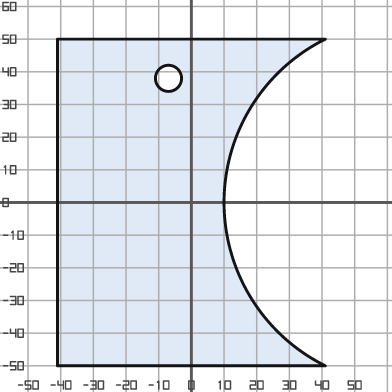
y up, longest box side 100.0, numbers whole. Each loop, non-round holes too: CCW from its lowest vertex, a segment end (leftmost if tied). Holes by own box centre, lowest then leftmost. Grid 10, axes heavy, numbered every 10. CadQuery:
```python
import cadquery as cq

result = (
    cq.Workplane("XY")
    .moveTo(-41.0, -50.0)
    .lineTo(41.0, -50.0)
    .threePointArc((10.0, 0.0), (41.0, 50.0))
    .lineTo(-41.0, 50.0)
    .close()
    .moveTo(-7.0, 38.0)
    .circle(4.0)
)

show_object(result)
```